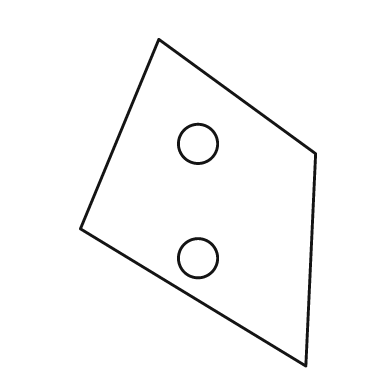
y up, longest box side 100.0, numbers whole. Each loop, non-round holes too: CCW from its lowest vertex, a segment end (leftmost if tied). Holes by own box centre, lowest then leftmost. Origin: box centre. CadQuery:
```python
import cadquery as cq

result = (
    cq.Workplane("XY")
    .moveTo(33.0, -50.0)
    .lineTo(36.0, 15.0)
    .lineTo(-12.0, 50.0)
    .lineTo(-36.0, -8.0)
    .close()
    .moveTo(0.0, -17.0)
    .circle(6.0)
    .moveTo(0.0, 18.0)
    .circle(6.0)
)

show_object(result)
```